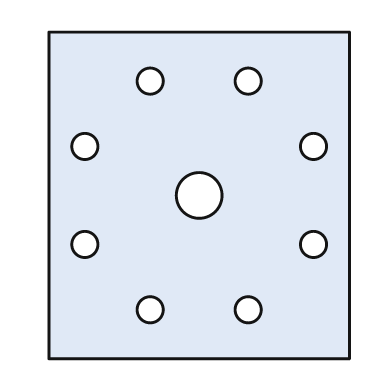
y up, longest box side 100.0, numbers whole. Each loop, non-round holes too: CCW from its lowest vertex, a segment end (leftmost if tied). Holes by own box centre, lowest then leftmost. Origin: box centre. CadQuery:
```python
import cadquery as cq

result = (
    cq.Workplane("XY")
    .moveTo(-46.0, -50.0)
    .lineTo(46.0, -50.0)
    .lineTo(46.0, 50.0)
    .lineTo(-46.0, 50.0)
    .close()
    .moveTo(-15.0, -35.0)
    .circle(4.0)
    .moveTo(15.0, -35.0)
    .circle(4.0)
    .moveTo(-35.0, -15.0)
    .circle(4.0)
    .moveTo(35.0, -15.0)
    .circle(4.0)
    .moveTo(0.0, 0.0)
    .circle(7.0)
    .moveTo(-35.0, 15.0)
    .circle(4.0)
    .moveTo(35.0, 15.0)
    .circle(4.0)
    .moveTo(-15.0, 35.0)
    .circle(4.0)
    .moveTo(15.0, 35.0)
    .circle(4.0)
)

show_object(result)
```